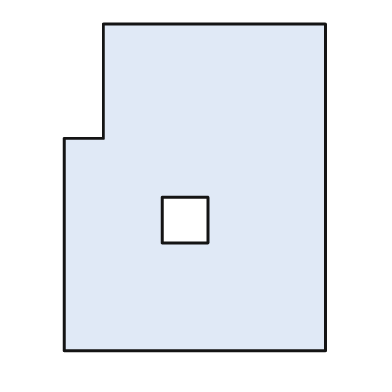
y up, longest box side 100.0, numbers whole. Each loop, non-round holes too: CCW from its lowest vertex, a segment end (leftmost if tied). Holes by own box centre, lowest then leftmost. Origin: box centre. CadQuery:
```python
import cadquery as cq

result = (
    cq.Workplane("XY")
    .moveTo(-40.0, -50.0)
    .lineTo(40.0, -50.0)
    .lineTo(40.0, 50.0)
    .lineTo(-28.0, 50.0)
    .lineTo(-28.0, 15.0)
    .lineTo(-40.0, 15.0)
    .close()
    .moveTo(-10.0, -17.0)
    .lineTo(4.0, -17.0)
    .lineTo(4.0, -3.0)
    .lineTo(-10.0, -3.0)
    .close()
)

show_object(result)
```